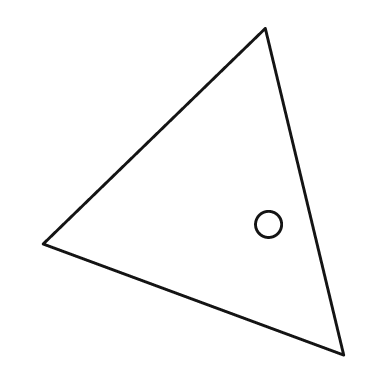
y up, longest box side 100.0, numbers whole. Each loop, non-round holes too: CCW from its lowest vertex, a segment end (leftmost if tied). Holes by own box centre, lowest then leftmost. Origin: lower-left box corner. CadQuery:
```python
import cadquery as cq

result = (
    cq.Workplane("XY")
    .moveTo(92.0, 0.0)
    .lineTo(68.0, 100.0)
    .lineTo(0.0, 34.0)
    .close()
    .moveTo(69.0, 40.0)
    .circle(4.0)
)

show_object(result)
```